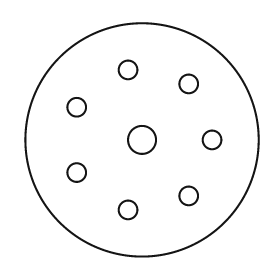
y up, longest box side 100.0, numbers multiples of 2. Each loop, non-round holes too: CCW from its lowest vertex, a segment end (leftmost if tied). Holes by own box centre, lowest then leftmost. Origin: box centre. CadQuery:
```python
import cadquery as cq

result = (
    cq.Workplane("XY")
    .moveTo(0.0, 0.0)
    .circle(50.0)
    .moveTo(-6.0, -30.0)
    .circle(4.0)
    .moveTo(20.0, -24.0)
    .circle(4.0)
    .moveTo(-28.0, -14.0)
    .circle(4.0)
    .moveTo(0.0, 0.0)
    .circle(6.0)
    .moveTo(30.0, 0.0)
    .circle(4.0)
    .moveTo(-28.0, 14.0)
    .circle(4.0)
    .moveTo(20.0, 24.0)
    .circle(4.0)
    .moveTo(-6.0, 30.0)
    .circle(4.0)
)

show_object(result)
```